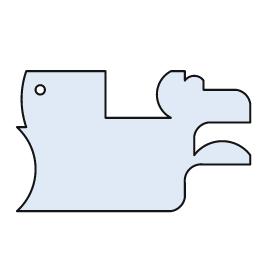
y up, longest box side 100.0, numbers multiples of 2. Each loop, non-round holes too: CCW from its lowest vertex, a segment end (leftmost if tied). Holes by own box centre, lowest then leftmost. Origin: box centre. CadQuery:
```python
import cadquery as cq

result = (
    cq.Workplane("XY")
    .moveTo(-50.0, -30.0)
    .lineTo(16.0, -30.0)
    .threePointArc((20.0, -28.0), (22.0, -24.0))
    .lineTo(22.0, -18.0)
    .threePointArc((24.0, -12.0), (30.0, -10.0))
    .lineTo(50.0, -10.0)
    .lineTo(50.0, -6.0)
    .threePointArc((38.0, 0.0), (26.0, -6.0))
    .lineTo(26.0, 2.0)
    .threePointArc((28.0, 6.0), (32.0, 8.0))
    .lineTo(50.0, 8.0)
    .lineTo(50.0, 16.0)
    .threePointArc((48.0, 20.0), (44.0, 22.0))
    .lineTo(30.0, 22.0)
    .lineTo(30.0, 26.0)
    .threePointArc((26.0, 28.0), (22.0, 26.0))
    .lineTo(22.0, 30.0)
    .lineTo(16.0, 30.0)
    .threePointArc((10.0, 20.0), (16.0, 10.0))
    .lineTo(-12.0, 10.0)
    .lineTo(-12.0, 30.0)
    .lineTo(-46.0, 30.0)
    .threePointArc((-48.0, 18.0), (-46.0, 6.0))
    .lineTo(-50.0, 6.0)
    .threePointArc((-42.0, -12.0), (-50.0, -30.0))
    .close()
    .moveTo(-40.0, 22.0)
    .circle(2.0)
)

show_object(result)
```